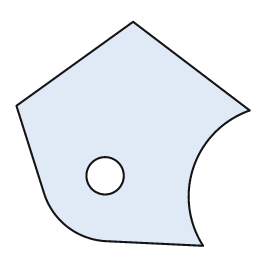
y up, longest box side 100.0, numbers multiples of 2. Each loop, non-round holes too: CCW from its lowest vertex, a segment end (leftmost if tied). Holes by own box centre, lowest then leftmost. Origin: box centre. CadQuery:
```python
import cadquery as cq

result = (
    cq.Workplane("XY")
    .moveTo(30.0, -48.0)
    .threePointArc((26.0, -14.0), (50.0, 10.0))
    .lineTo(0.0, 48.0)
    .lineTo(-50.0, 12.0)
    .lineTo(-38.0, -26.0)
    .threePointArc((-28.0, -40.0), (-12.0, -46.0))
    .close()
    .moveTo(-12.0, -18.0)
    .circle(8.0)
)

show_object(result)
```